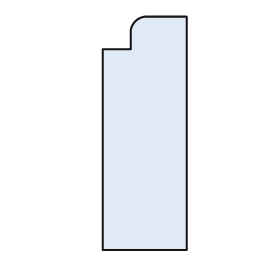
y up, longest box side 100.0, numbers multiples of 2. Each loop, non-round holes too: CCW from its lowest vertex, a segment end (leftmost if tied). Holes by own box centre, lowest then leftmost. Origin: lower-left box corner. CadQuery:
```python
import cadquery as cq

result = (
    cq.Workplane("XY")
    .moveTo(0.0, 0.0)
    .lineTo(36.0, 0.0)
    .lineTo(36.0, 100.0)
    .lineTo(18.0, 100.0)
    .threePointArc((14.0, 98.0), (12.0, 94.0))
    .lineTo(12.0, 86.0)
    .lineTo(0.0, 86.0)
    .close()
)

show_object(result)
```